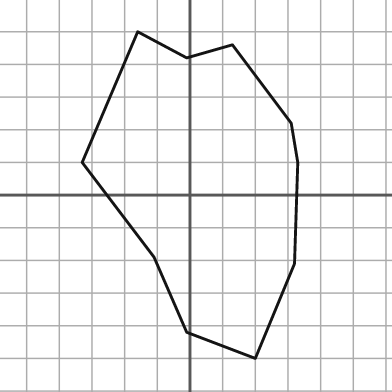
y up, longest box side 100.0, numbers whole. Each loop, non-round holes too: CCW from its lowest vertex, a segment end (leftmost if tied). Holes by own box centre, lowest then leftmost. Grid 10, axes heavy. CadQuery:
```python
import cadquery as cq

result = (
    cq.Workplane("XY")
    .moveTo(20.0, -50.0)
    .lineTo(32.0, -21.0)
    .lineTo(33.0, 10.0)
    .lineTo(31.0, 22.0)
    .lineTo(13.0, 46.0)
    .lineTo(-1.0, 42.0)
    .lineTo(-16.0, 50.0)
    .lineTo(-33.0, 10.0)
    .lineTo(-11.0, -19.0)
    .lineTo(-1.0, -42.0)
    .close()
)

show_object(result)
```